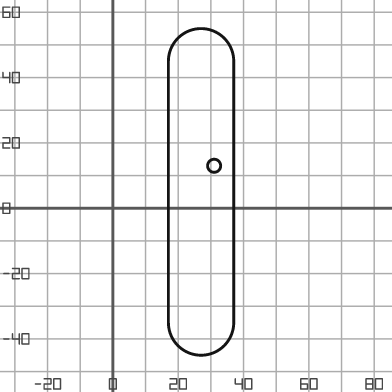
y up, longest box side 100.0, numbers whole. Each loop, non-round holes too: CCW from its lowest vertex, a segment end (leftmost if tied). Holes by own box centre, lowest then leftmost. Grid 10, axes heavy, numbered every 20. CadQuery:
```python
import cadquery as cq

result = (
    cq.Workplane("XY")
    .moveTo(17.0, -35.0)
    .threePointArc((27.0, -45.0), (37.0, -35.0))
    .lineTo(37.0, 45.0)
    .threePointArc((27.0, 55.0), (17.0, 45.0))
    .close()
    .moveTo(31.0, 13.0)
    .circle(2.0)
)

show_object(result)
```